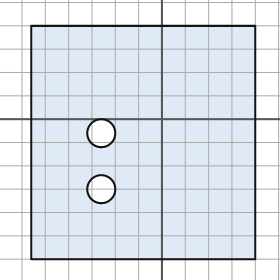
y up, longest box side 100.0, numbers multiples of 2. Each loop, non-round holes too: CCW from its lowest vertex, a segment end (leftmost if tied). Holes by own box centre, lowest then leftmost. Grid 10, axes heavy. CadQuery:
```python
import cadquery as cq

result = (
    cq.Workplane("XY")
    .moveTo(-56.0, -60.0)
    .lineTo(40.0, -60.0)
    .lineTo(40.0, 40.0)
    .lineTo(-56.0, 40.0)
    .close()
    .moveTo(-26.0, -30.0)
    .circle(6.0)
    .moveTo(-26.0, -6.0)
    .circle(6.0)
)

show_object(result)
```